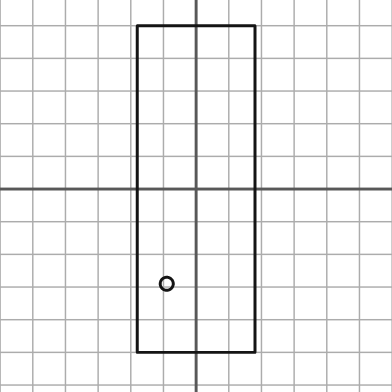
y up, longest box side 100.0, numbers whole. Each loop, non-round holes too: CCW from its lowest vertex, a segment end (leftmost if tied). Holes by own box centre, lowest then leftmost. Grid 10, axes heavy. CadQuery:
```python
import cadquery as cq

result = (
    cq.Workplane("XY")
    .moveTo(-18.0, -50.0)
    .lineTo(18.0, -50.0)
    .lineTo(18.0, 50.0)
    .lineTo(-18.0, 50.0)
    .close()
    .moveTo(-9.0, -29.0)
    .circle(2.0)
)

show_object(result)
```